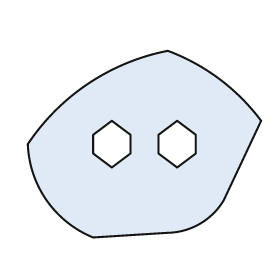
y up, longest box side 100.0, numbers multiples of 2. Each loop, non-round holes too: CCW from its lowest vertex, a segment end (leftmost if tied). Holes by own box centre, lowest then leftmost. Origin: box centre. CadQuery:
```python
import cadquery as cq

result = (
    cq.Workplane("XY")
    .moveTo(-22.0, -40.0)
    .lineTo(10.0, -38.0)
    .threePointArc((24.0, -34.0), (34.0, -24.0))
    .lineTo(50.0, 10.0)
    .threePointArc((32.0, 28.0), (10.0, 40.0))
    .threePointArc((-24.0, 26.0), (-50.0, 0.0))
    .threePointArc((-42.0, -24.0), (-22.0, -40.0))
    .close()
    .moveTo(-14.0, -10.0)
    .lineTo(-6.0, -4.0)
    .lineTo(-6.0, 4.0)
    .lineTo(-14.0, 10.0)
    .lineTo(-22.0, 4.0)
    .lineTo(-22.0, -4.0)
    .close()
    .moveTo(14.0, -10.0)
    .lineTo(22.0, -4.0)
    .lineTo(22.0, 4.0)
    .lineTo(14.0, 10.0)
    .lineTo(6.0, 4.0)
    .lineTo(6.0, -4.0)
    .close()
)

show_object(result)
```